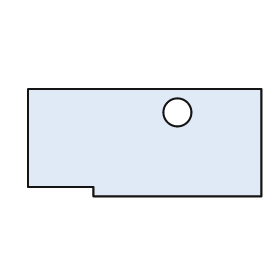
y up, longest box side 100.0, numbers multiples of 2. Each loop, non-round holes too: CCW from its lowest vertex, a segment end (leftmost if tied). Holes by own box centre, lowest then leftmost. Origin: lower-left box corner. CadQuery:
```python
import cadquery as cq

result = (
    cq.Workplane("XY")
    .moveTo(28.0, 0.0)
    .lineTo(100.0, 0.0)
    .lineTo(100.0, 46.0)
    .lineTo(0.0, 46.0)
    .lineTo(0.0, 4.0)
    .lineTo(28.0, 4.0)
    .close()
    .moveTo(64.0, 36.0)
    .circle(6.0)
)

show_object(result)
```